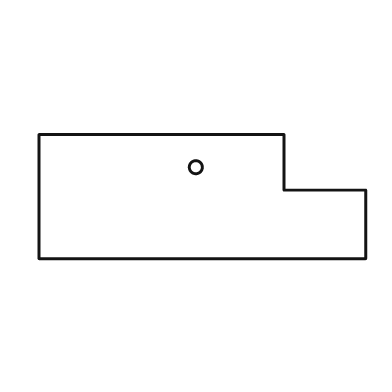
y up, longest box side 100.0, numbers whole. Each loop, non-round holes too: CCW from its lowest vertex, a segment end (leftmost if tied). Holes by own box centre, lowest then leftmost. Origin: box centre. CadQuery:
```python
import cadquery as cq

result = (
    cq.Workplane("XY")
    .moveTo(-50.0, -19.0)
    .lineTo(50.0, -19.0)
    .lineTo(50.0, 2.0)
    .lineTo(25.0, 2.0)
    .lineTo(25.0, 19.0)
    .lineTo(-50.0, 19.0)
    .close()
    .moveTo(-2.0, 9.0)
    .circle(2.0)
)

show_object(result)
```